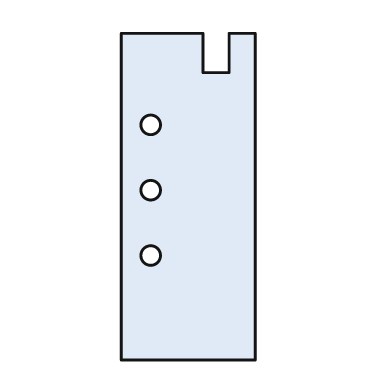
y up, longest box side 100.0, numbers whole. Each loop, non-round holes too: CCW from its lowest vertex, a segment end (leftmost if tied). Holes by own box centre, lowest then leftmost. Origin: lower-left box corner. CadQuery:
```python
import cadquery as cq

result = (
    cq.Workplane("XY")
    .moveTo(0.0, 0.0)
    .lineTo(41.0, 0.0)
    .lineTo(41.0, 100.0)
    .lineTo(33.0, 100.0)
    .lineTo(33.0, 88.0)
    .lineTo(25.0, 88.0)
    .lineTo(25.0, 100.0)
    .lineTo(0.0, 100.0)
    .close()
    .moveTo(9.0, 32.0)
    .circle(3.0)
    .moveTo(9.0, 52.0)
    .circle(3.0)
    .moveTo(9.0, 72.0)
    .circle(3.0)
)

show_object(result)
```